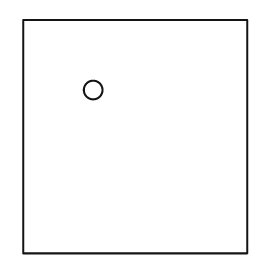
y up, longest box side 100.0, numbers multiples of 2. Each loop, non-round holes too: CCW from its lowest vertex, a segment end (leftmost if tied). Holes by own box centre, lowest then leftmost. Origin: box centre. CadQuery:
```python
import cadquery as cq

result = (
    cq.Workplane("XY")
    .moveTo(-48.0, -50.0)
    .lineTo(48.0, -50.0)
    .lineTo(48.0, 50.0)
    .lineTo(-48.0, 50.0)
    .close()
    .moveTo(-18.0, 20.0)
    .circle(4.0)
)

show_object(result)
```